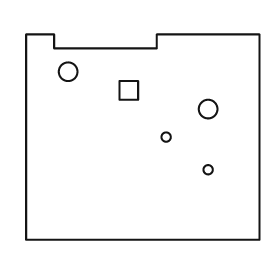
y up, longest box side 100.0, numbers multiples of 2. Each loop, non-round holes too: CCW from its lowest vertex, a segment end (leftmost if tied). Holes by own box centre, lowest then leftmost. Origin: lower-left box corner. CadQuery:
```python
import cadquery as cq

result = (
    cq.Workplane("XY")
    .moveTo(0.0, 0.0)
    .lineTo(100.0, 0.0)
    .lineTo(100.0, 88.0)
    .lineTo(56.0, 88.0)
    .lineTo(56.0, 82.0)
    .lineTo(12.0, 82.0)
    .lineTo(12.0, 88.0)
    .lineTo(0.0, 88.0)
    .close()
    .moveTo(78.0, 30.0)
    .circle(2.0)
    .moveTo(60.0, 44.0)
    .circle(2.0)
    .moveTo(78.0, 56.0)
    .circle(4.0)
    .moveTo(40.0, 60.0)
    .lineTo(48.0, 60.0)
    .lineTo(48.0, 68.0)
    .lineTo(40.0, 68.0)
    .close()
    .moveTo(18.0, 72.0)
    .circle(4.0)
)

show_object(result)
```